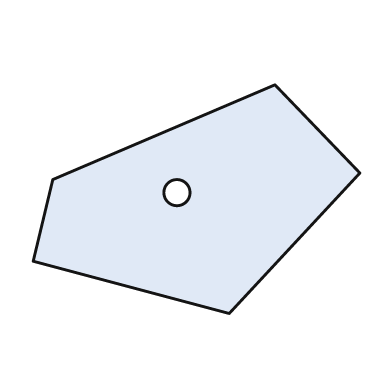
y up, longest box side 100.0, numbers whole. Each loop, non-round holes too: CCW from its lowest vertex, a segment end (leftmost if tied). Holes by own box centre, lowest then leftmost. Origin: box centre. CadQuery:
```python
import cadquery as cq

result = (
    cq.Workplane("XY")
    .moveTo(10.0, -35.0)
    .lineTo(50.0, 8.0)
    .lineTo(24.0, 35.0)
    .lineTo(-44.0, 6.0)
    .lineTo(-50.0, -19.0)
    .close()
    .moveTo(-6.0, 2.0)
    .circle(4.0)
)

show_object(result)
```